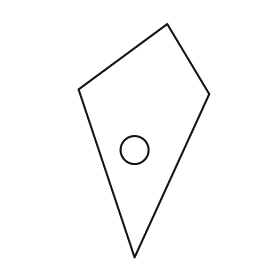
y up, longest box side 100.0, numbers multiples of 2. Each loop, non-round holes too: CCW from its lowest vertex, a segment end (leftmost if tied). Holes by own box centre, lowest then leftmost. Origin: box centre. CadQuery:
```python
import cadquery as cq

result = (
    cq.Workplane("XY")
    .moveTo(-4.0, -50.0)
    .lineTo(28.0, 20.0)
    .lineTo(10.0, 50.0)
    .lineTo(-28.0, 22.0)
    .close()
    .moveTo(-4.0, -4.0)
    .circle(6.0)
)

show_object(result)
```